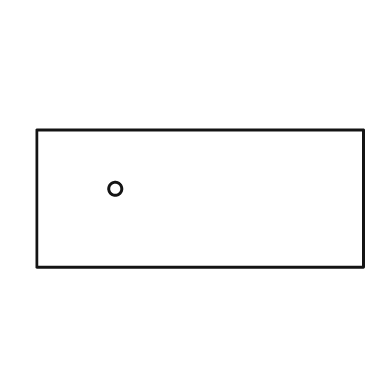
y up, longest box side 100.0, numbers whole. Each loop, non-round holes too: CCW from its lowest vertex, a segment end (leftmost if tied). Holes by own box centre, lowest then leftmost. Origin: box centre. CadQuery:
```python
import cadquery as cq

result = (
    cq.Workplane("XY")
    .moveTo(-50.0, -21.0)
    .lineTo(50.0, -21.0)
    .lineTo(50.0, 21.0)
    .lineTo(-50.0, 21.0)
    .close()
    .moveTo(-26.0, 3.0)
    .circle(2.0)
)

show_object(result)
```